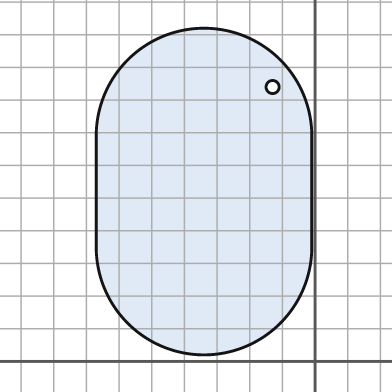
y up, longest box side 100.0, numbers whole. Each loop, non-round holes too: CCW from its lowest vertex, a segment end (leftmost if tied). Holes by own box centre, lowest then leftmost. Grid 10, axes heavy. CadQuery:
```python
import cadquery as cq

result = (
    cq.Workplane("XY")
    .moveTo(-67.0, 35.0)
    .threePointArc((-34.0, 2.0), (-1.0, 35.0))
    .lineTo(-1.0, 69.0)
    .threePointArc((-34.0, 102.0), (-67.0, 69.0))
    .close()
    .moveTo(-13.0, 84.0)
    .circle(2.0)
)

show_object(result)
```